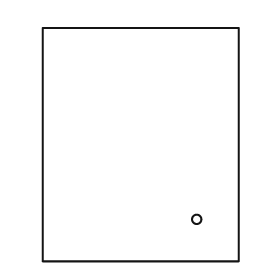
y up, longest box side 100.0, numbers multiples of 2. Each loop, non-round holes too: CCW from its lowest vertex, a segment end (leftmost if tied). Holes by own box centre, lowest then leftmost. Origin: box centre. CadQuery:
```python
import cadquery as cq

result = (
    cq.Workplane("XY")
    .moveTo(-42.0, -50.0)
    .lineTo(42.0, -50.0)
    .lineTo(42.0, 50.0)
    .lineTo(-42.0, 50.0)
    .close()
    .moveTo(24.0, -32.0)
    .circle(2.0)
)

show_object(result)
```